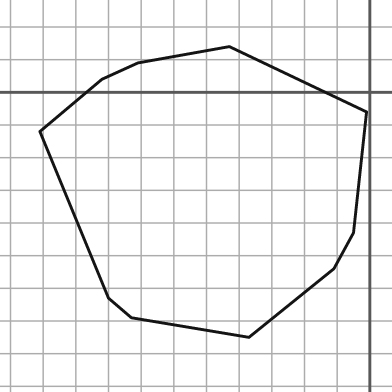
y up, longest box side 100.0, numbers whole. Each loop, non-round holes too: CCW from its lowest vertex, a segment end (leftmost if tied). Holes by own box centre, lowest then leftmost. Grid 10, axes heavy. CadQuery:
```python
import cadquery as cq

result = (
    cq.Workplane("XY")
    .moveTo(-37.0, -75.0)
    .lineTo(-11.0, -54.0)
    .lineTo(-5.0, -43.0)
    .lineTo(-1.0, -6.0)
    .lineTo(-43.0, 14.0)
    .lineTo(-71.0, 9.0)
    .lineTo(-82.0, 4.0)
    .lineTo(-101.0, -12.0)
    .lineTo(-80.0, -63.0)
    .lineTo(-73.0, -69.0)
    .close()
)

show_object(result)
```